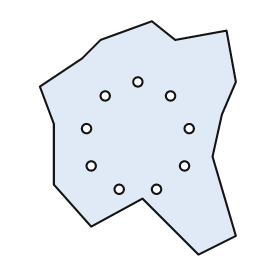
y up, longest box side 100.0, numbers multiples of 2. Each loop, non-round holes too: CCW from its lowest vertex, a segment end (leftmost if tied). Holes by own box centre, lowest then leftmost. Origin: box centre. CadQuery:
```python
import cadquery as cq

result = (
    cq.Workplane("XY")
    .moveTo(26.0, -50.0)
    .lineTo(42.0, -42.0)
    .lineTo(32.0, -8.0)
    .lineTo(36.0, 10.0)
    .lineTo(42.0, 24.0)
    .lineTo(38.0, 46.0)
    .lineTo(16.0, 42.0)
    .lineTo(6.0, 50.0)
    .lineTo(-16.0, 42.0)
    .lineTo(-24.0, 34.0)
    .lineTo(-42.0, 22.0)
    .lineTo(-36.0, 6.0)
    .lineTo(-36.0, -20.0)
    .lineTo(-20.0, -38.0)
    .lineTo(2.0, -26.0)
    .close()
    .moveTo(-8.0, -22.0)
    .circle(2.0)
    .moveTo(8.0, -22.0)
    .circle(2.0)
    .moveTo(-20.0, -12.0)
    .circle(2.0)
    .moveTo(20.0, -12.0)
    .circle(2.0)
    .moveTo(-22.0, 4.0)
    .circle(2.0)
    .moveTo(22.0, 4.0)
    .circle(2.0)
    .moveTo(-14.0, 18.0)
    .circle(2.0)
    .moveTo(14.0, 18.0)
    .circle(2.0)
    .moveTo(0.0, 24.0)
    .circle(2.0)
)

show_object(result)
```